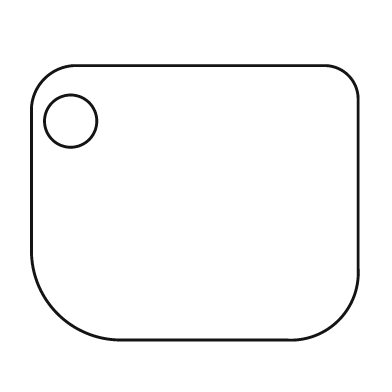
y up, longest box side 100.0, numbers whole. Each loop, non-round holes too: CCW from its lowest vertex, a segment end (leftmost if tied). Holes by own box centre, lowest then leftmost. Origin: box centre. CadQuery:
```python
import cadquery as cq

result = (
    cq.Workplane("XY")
    .moveTo(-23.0, -42.0)
    .lineTo(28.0, -42.0)
    .threePointArc((44.0, -36.0), (50.0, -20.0))
    .lineTo(50.0, 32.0)
    .threePointArc((47.0, 39.0), (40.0, 42.0))
    .lineTo(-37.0, 42.0)
    .threePointArc((-46.0, 38.0), (-50.0, 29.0))
    .lineTo(-50.0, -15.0)
    .threePointArc((-42.0, -34.0), (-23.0, -42.0))
    .close()
    .moveTo(-38.0, 25.0)
    .circle(8.0)
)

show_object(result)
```